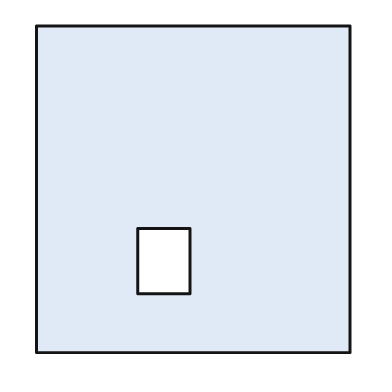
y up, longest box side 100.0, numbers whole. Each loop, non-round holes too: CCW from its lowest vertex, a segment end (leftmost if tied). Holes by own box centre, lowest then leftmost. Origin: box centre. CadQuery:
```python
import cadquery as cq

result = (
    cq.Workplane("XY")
    .moveTo(-48.0, -50.0)
    .lineTo(48.0, -50.0)
    .lineTo(48.0, 50.0)
    .lineTo(-48.0, 50.0)
    .close()
    .moveTo(-17.0, -32.0)
    .lineTo(-1.0, -32.0)
    .lineTo(-1.0, -12.0)
    .lineTo(-17.0, -12.0)
    .close()
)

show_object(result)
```